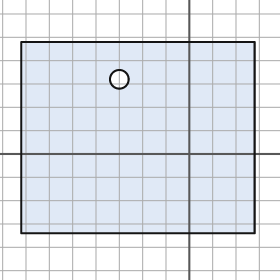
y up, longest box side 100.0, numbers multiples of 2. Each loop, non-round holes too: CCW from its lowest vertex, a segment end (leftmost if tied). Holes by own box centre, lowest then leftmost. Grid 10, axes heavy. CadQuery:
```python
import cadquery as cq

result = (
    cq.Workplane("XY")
    .moveTo(-72.0, -34.0)
    .lineTo(28.0, -34.0)
    .lineTo(28.0, 48.0)
    .lineTo(-72.0, 48.0)
    .close()
    .moveTo(-30.0, 32.0)
    .circle(4.0)
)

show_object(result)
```